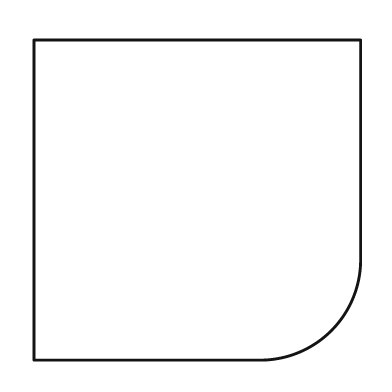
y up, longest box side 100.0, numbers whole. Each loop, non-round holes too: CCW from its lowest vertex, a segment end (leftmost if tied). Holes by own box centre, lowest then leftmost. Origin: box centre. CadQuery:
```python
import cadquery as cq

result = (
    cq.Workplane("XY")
    .moveTo(-50.0, -49.0)
    .lineTo(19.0, -49.0)
    .threePointArc((41.0, -40.0), (50.0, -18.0))
    .lineTo(50.0, 49.0)
    .lineTo(-50.0, 49.0)
    .close()
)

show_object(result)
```